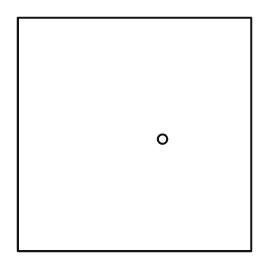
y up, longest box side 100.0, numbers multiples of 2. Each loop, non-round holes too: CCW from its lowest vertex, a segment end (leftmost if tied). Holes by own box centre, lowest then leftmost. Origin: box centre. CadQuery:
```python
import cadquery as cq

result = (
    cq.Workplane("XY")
    .moveTo(-50.0, -50.0)
    .lineTo(50.0, -50.0)
    .lineTo(50.0, 50.0)
    .lineTo(-50.0, 50.0)
    .close()
    .moveTo(12.0, -2.0)
    .circle(2.0)
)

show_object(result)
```